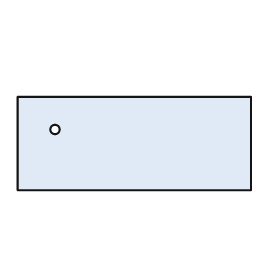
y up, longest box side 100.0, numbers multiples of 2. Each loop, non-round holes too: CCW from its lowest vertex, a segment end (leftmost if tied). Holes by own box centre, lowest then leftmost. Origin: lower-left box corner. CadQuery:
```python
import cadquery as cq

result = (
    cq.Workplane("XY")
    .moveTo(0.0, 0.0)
    .lineTo(100.0, 0.0)
    .lineTo(100.0, 40.0)
    .lineTo(0.0, 40.0)
    .close()
    .moveTo(16.0, 26.0)
    .circle(2.0)
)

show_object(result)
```